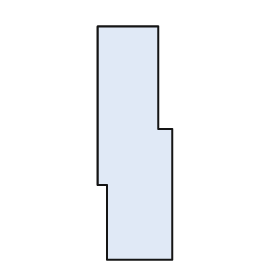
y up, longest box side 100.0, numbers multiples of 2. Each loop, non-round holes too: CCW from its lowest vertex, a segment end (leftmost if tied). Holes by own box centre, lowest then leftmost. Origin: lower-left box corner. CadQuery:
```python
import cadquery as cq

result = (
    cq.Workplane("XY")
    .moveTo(4.0, 0.0)
    .lineTo(32.0, 0.0)
    .lineTo(32.0, 56.0)
    .lineTo(26.0, 56.0)
    .lineTo(26.0, 100.0)
    .lineTo(0.0, 100.0)
    .lineTo(0.0, 32.0)
    .lineTo(4.0, 32.0)
    .close()
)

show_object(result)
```